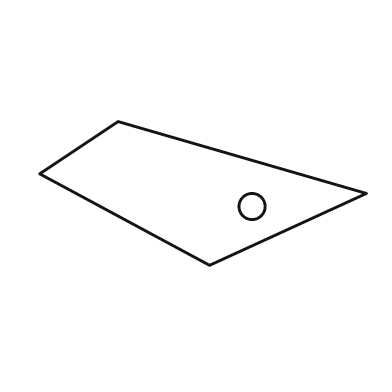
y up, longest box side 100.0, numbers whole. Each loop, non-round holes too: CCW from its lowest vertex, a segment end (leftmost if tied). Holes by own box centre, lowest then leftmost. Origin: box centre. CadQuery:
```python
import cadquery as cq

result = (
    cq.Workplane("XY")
    .moveTo(2.0, -22.0)
    .lineTo(50.0, 0.0)
    .lineTo(-26.0, 22.0)
    .lineTo(-50.0, 6.0)
    .close()
    .moveTo(15.0, -4.0)
    .circle(4.0)
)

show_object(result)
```